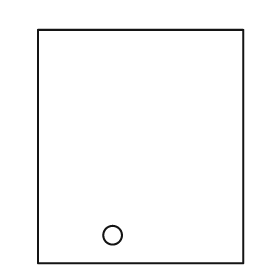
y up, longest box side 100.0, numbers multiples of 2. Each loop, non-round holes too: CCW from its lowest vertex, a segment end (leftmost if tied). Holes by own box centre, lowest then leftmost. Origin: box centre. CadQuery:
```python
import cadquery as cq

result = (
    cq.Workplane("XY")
    .moveTo(-44.0, -50.0)
    .lineTo(44.0, -50.0)
    .lineTo(44.0, 50.0)
    .lineTo(-44.0, 50.0)
    .close()
    .moveTo(-12.0, -38.0)
    .circle(4.0)
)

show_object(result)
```